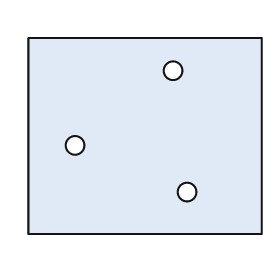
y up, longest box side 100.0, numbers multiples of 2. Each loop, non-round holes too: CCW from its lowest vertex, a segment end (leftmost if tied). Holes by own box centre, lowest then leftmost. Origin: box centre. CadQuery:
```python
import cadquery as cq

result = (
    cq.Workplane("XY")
    .moveTo(-50.0, -42.0)
    .lineTo(50.0, -42.0)
    .lineTo(50.0, 42.0)
    .lineTo(-50.0, 42.0)
    .close()
    .moveTo(18.0, -24.0)
    .circle(4.0)
    .moveTo(-30.0, -4.0)
    .circle(4.0)
    .moveTo(12.0, 28.0)
    .circle(4.0)
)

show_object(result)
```